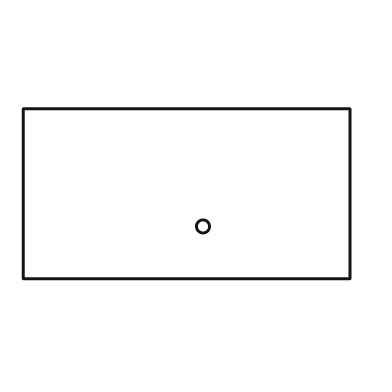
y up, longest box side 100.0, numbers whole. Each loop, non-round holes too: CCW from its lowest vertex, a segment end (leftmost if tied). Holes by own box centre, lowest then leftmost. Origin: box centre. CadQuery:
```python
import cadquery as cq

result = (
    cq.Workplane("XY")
    .moveTo(-50.0, -26.0)
    .lineTo(50.0, -26.0)
    .lineTo(50.0, 26.0)
    .lineTo(-50.0, 26.0)
    .close()
    .moveTo(5.0, -10.0)
    .circle(2.0)
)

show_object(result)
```